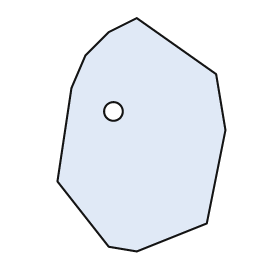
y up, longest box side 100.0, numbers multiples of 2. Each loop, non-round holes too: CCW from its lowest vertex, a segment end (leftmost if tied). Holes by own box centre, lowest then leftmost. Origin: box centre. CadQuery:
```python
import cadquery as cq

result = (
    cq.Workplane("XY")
    .moveTo(-2.0, -50.0)
    .lineTo(28.0, -38.0)
    .lineTo(36.0, 2.0)
    .lineTo(32.0, 26.0)
    .lineTo(-2.0, 50.0)
    .lineTo(-14.0, 44.0)
    .lineTo(-24.0, 34.0)
    .lineTo(-30.0, 20.0)
    .lineTo(-36.0, -20.0)
    .lineTo(-14.0, -48.0)
    .close()
    .moveTo(-12.0, 10.0)
    .circle(4.0)
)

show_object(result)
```